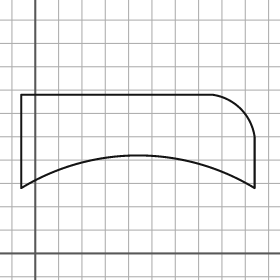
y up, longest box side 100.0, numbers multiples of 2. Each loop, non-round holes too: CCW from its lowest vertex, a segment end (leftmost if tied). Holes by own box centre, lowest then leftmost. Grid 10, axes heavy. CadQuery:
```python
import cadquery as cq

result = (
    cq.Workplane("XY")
    .moveTo(-6.0, 28.0)
    .threePointArc((44.0, 42.0), (94.0, 28.0))
    .lineTo(94.0, 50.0)
    .threePointArc((88.0, 62.0), (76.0, 68.0))
    .lineTo(-6.0, 68.0)
    .close()
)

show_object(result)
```